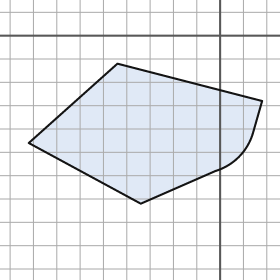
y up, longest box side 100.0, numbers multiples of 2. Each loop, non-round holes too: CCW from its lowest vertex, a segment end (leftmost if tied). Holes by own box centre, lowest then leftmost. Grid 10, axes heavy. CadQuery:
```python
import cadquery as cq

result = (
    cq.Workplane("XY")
    .moveTo(-34.0, -72.0)
    .lineTo(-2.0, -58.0)
    .threePointArc((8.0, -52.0), (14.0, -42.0))
    .lineTo(18.0, -28.0)
    .lineTo(-44.0, -12.0)
    .lineTo(-82.0, -46.0)
    .close()
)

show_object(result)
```